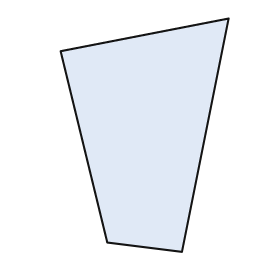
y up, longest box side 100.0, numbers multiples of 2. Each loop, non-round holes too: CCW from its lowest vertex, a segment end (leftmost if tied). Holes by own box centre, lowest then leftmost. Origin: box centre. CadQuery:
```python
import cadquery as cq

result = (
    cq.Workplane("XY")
    .moveTo(16.0, -50.0)
    .lineTo(36.0, 50.0)
    .lineTo(-36.0, 36.0)
    .lineTo(-16.0, -46.0)
    .close()
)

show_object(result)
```